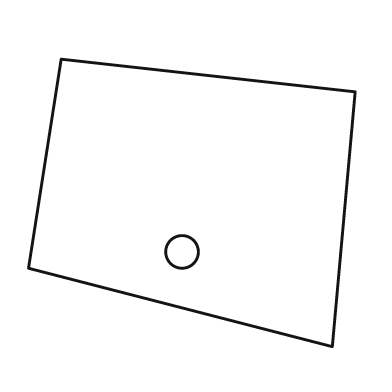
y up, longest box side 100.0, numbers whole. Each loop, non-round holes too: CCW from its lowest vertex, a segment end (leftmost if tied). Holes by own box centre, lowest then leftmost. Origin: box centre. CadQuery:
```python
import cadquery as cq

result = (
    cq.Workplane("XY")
    .moveTo(43.0, -44.0)
    .lineTo(50.0, 34.0)
    .lineTo(-40.0, 44.0)
    .lineTo(-50.0, -20.0)
    .close()
    .moveTo(-3.0, -15.0)
    .circle(5.0)
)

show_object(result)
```